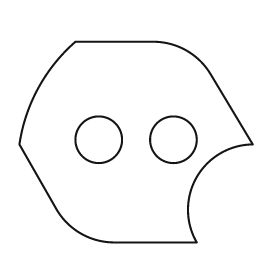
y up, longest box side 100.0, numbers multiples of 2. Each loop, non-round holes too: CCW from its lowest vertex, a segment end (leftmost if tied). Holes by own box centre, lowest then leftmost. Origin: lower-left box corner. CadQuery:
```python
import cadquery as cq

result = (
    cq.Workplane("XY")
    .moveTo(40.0, 0.0)
    .lineTo(76.0, 0.0)
    .threePointArc((76.0, 28.0), (100.0, 42.0))
    .lineTo(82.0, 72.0)
    .threePointArc((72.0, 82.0), (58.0, 86.0))
    .lineTo(24.0, 86.0)
    .threePointArc((8.0, 66.0), (0.0, 42.0))
    .lineTo(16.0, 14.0)
    .threePointArc((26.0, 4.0), (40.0, 0.0))
    .close()
    .moveTo(34.0, 44.0)
    .circle(10.0)
    .moveTo(66.0, 44.0)
    .circle(10.0)
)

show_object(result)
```